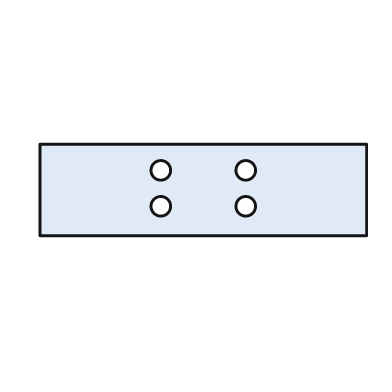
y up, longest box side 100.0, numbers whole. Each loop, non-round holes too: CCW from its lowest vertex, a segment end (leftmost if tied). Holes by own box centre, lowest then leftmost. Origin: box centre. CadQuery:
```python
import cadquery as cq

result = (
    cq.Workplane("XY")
    .moveTo(-50.0, -14.0)
    .lineTo(50.0, -14.0)
    .lineTo(50.0, 14.0)
    .lineTo(-50.0, 14.0)
    .close()
    .moveTo(-13.0, -5.0)
    .circle(3.0)
    .moveTo(13.0, -5.0)
    .circle(3.0)
    .moveTo(-13.0, 6.0)
    .circle(3.0)
    .moveTo(13.0, 6.0)
    .circle(3.0)
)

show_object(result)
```